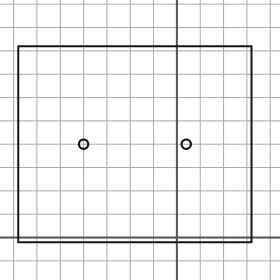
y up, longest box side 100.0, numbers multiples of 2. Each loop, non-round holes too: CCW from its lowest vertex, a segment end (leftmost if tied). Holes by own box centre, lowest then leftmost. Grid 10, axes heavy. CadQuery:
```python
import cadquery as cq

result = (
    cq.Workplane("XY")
    .moveTo(-68.0, -2.0)
    .lineTo(32.0, -2.0)
    .lineTo(32.0, 82.0)
    .lineTo(-68.0, 82.0)
    .close()
    .moveTo(-40.0, 40.0)
    .circle(2.0)
    .moveTo(4.0, 40.0)
    .circle(2.0)
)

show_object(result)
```